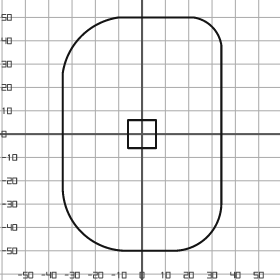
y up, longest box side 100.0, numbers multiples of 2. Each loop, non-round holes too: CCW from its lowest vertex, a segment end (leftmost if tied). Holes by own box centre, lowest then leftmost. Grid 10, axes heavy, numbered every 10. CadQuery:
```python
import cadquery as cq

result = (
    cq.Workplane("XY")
    .moveTo(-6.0, -50.0)
    .lineTo(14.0, -50.0)
    .threePointArc((28.0, -44.0), (34.0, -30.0))
    .lineTo(34.0, 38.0)
    .threePointArc((30.0, 46.0), (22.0, 50.0))
    .lineTo(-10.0, 50.0)
    .threePointArc((-26.0, 42.0), (-34.0, 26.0))
    .lineTo(-34.0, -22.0)
    .threePointArc((-26.0, -42.0), (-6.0, -50.0))
    .close()
    .moveTo(-6.0, -6.0)
    .lineTo(6.0, -6.0)
    .lineTo(6.0, 6.0)
    .lineTo(-6.0, 6.0)
    .close()
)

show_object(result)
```